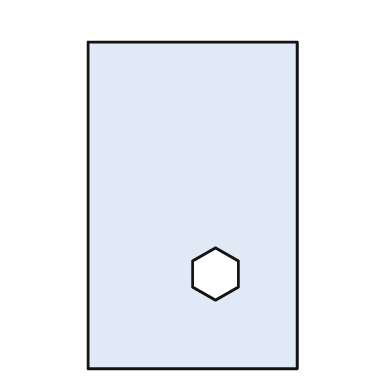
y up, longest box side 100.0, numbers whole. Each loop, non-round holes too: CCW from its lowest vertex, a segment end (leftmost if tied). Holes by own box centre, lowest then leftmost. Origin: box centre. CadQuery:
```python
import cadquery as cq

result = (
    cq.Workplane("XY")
    .moveTo(-32.0, -50.0)
    .lineTo(32.0, -50.0)
    .lineTo(32.0, 50.0)
    .lineTo(-32.0, 50.0)
    .close()
    .moveTo(7.0, -29.0)
    .lineTo(14.0, -25.0)
    .lineTo(14.0, -17.0)
    .lineTo(7.0, -13.0)
    .lineTo(0.0, -17.0)
    .lineTo(0.0, -25.0)
    .close()
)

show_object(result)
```